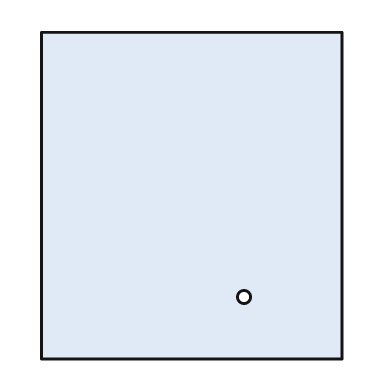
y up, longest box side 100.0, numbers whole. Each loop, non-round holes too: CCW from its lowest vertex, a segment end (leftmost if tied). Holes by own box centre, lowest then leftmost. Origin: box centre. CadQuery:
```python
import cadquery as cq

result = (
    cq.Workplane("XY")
    .moveTo(-46.0, -50.0)
    .lineTo(46.0, -50.0)
    .lineTo(46.0, 50.0)
    .lineTo(-46.0, 50.0)
    .close()
    .moveTo(16.0, -31.0)
    .circle(2.0)
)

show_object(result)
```